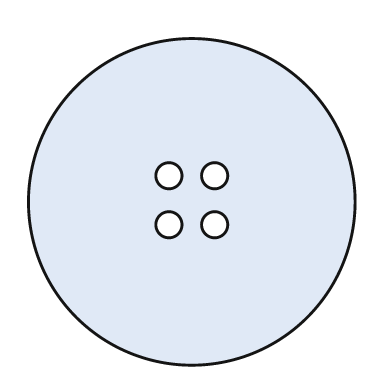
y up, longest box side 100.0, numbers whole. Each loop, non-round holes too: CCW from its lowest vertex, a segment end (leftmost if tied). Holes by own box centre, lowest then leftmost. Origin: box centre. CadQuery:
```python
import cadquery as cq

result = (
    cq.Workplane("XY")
    .moveTo(0.0, 0.0)
    .circle(50.0)
    .moveTo(-7.0, -7.0)
    .circle(4.0)
    .moveTo(7.0, -7.0)
    .circle(4.0)
    .moveTo(-7.0, 8.0)
    .circle(4.0)
    .moveTo(7.0, 8.0)
    .circle(4.0)
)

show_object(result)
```